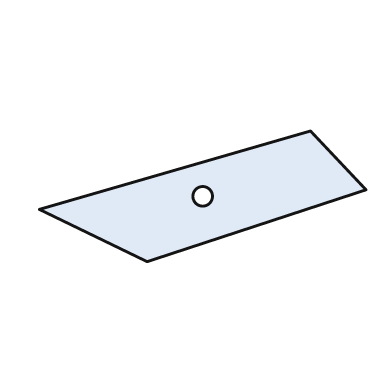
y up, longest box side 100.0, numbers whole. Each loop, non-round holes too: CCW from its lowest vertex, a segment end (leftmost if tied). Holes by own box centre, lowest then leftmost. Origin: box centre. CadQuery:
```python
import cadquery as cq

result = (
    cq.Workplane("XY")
    .moveTo(-17.0, -20.0)
    .lineTo(50.0, 2.0)
    .lineTo(33.0, 20.0)
    .lineTo(-50.0, -4.0)
    .close()
    .moveTo(0.0, 0.0)
    .circle(3.0)
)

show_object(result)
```